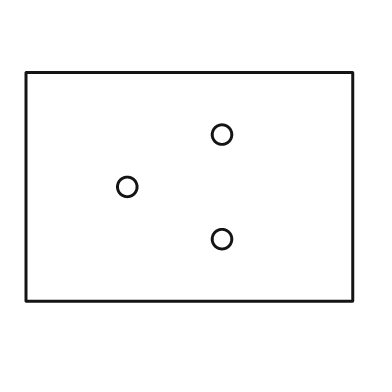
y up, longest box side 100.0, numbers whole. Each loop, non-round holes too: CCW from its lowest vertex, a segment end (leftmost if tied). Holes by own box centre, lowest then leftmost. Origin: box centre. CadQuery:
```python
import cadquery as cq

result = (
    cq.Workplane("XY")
    .moveTo(-50.0, -35.0)
    .lineTo(50.0, -35.0)
    .lineTo(50.0, 35.0)
    .lineTo(-50.0, 35.0)
    .close()
    .moveTo(10.0, -16.0)
    .circle(3.0)
    .moveTo(-19.0, 0.0)
    .circle(3.0)
    .moveTo(10.0, 16.0)
    .circle(3.0)
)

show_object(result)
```